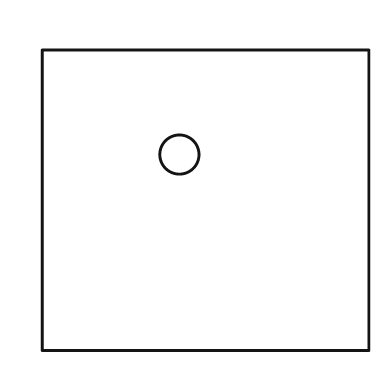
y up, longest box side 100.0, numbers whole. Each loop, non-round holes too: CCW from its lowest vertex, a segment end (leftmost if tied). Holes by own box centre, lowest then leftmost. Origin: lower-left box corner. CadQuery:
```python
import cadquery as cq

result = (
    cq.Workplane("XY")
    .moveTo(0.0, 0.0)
    .lineTo(100.0, 0.0)
    .lineTo(100.0, 92.0)
    .lineTo(0.0, 92.0)
    .close()
    .moveTo(42.0, 60.0)
    .circle(6.0)
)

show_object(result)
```